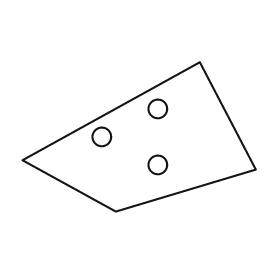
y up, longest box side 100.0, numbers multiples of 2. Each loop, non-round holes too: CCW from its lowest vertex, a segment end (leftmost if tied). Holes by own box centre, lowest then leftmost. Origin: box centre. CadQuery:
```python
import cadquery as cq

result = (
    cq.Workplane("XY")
    .moveTo(-10.0, -32.0)
    .lineTo(50.0, -14.0)
    .lineTo(26.0, 32.0)
    .lineTo(-50.0, -10.0)
    .close()
    .moveTo(8.0, -12.0)
    .circle(4.0)
    .moveTo(-16.0, 0.0)
    .circle(4.0)
    .moveTo(8.0, 12.0)
    .circle(4.0)
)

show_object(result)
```